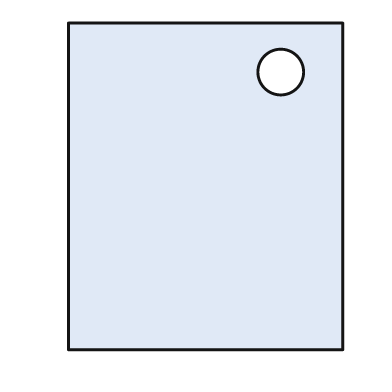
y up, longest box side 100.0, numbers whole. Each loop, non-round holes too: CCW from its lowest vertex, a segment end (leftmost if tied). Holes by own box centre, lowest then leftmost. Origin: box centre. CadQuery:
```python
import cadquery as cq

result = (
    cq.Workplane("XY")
    .moveTo(-42.0, -50.0)
    .lineTo(42.0, -50.0)
    .lineTo(42.0, 50.0)
    .lineTo(-42.0, 50.0)
    .close()
    .moveTo(23.0, 35.0)
    .circle(7.0)
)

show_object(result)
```